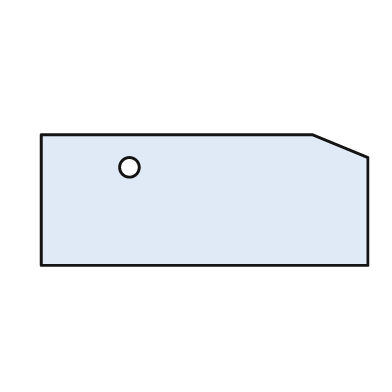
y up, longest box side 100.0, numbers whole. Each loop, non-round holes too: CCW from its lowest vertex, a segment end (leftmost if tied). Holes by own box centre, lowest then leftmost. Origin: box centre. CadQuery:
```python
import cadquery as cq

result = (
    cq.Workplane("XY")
    .moveTo(-50.0, -20.0)
    .lineTo(50.0, -20.0)
    .lineTo(50.0, 13.0)
    .lineTo(33.0, 20.0)
    .lineTo(-50.0, 20.0)
    .close()
    .moveTo(-23.0, 10.0)
    .circle(3.0)
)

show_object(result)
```